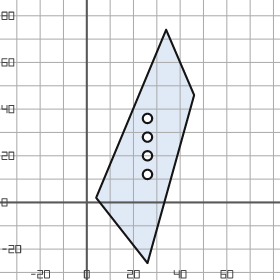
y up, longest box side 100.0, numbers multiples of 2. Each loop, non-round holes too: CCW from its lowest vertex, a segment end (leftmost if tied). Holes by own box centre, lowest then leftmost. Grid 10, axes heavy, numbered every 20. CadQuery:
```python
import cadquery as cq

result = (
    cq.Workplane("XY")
    .moveTo(26.0, -26.0)
    .lineTo(46.0, 46.0)
    .lineTo(34.0, 74.0)
    .lineTo(4.0, 2.0)
    .close()
    .moveTo(26.0, 12.0)
    .circle(2.0)
    .moveTo(26.0, 20.0)
    .circle(2.0)
    .moveTo(26.0, 28.0)
    .circle(2.0)
    .moveTo(26.0, 36.0)
    .circle(2.0)
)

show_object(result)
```